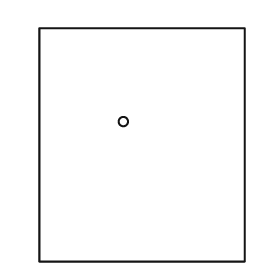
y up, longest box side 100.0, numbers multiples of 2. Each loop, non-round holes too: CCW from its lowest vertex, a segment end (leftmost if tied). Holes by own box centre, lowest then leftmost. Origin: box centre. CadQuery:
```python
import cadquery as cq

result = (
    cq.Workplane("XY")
    .moveTo(-44.0, -50.0)
    .lineTo(44.0, -50.0)
    .lineTo(44.0, 50.0)
    .lineTo(-44.0, 50.0)
    .close()
    .moveTo(-8.0, 10.0)
    .circle(2.0)
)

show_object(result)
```